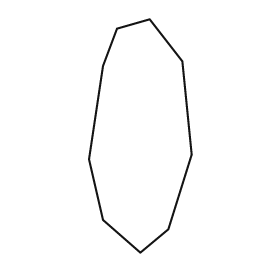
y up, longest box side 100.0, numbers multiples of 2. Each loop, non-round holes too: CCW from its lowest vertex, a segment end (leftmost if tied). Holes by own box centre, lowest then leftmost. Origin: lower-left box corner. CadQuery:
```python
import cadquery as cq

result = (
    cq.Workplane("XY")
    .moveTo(22.0, 0.0)
    .lineTo(34.0, 10.0)
    .lineTo(44.0, 42.0)
    .lineTo(40.0, 82.0)
    .lineTo(26.0, 100.0)
    .lineTo(12.0, 96.0)
    .lineTo(6.0, 80.0)
    .lineTo(0.0, 40.0)
    .lineTo(6.0, 14.0)
    .close()
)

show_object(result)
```